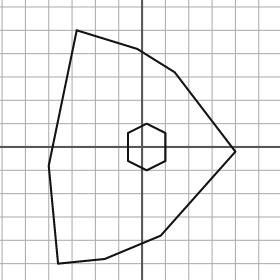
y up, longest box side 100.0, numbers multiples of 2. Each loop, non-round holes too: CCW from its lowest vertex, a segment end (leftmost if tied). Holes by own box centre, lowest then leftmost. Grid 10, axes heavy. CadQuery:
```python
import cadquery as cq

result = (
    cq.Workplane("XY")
    .moveTo(-36.0, -50.0)
    .lineTo(-16.0, -48.0)
    .lineTo(8.0, -38.0)
    .lineTo(40.0, -2.0)
    .lineTo(14.0, 32.0)
    .lineTo(-2.0, 42.0)
    .lineTo(-28.0, 50.0)
    .lineTo(-40.0, -8.0)
    .close()
    .moveTo(2.0, -10.0)
    .lineTo(10.0, -6.0)
    .lineTo(10.0, 6.0)
    .lineTo(2.0, 10.0)
    .lineTo(-6.0, 6.0)
    .lineTo(-6.0, -6.0)
    .close()
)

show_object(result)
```